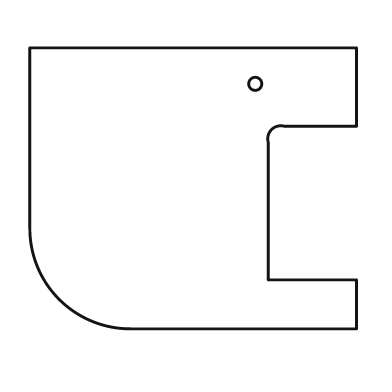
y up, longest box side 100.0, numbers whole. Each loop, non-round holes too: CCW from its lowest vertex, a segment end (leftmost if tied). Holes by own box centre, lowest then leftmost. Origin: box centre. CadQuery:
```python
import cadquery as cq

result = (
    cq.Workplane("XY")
    .moveTo(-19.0, -43.0)
    .lineTo(50.0, -43.0)
    .lineTo(50.0, -28.0)
    .lineTo(23.0, -28.0)
    .lineTo(23.0, 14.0)
    .threePointArc((24.0, 18.0), (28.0, 19.0))
    .lineTo(50.0, 19.0)
    .lineTo(50.0, 43.0)
    .lineTo(-50.0, 43.0)
    .lineTo(-50.0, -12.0)
    .threePointArc((-41.0, -34.0), (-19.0, -43.0))
    .close()
    .moveTo(19.0, 32.0)
    .circle(2.0)
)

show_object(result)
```